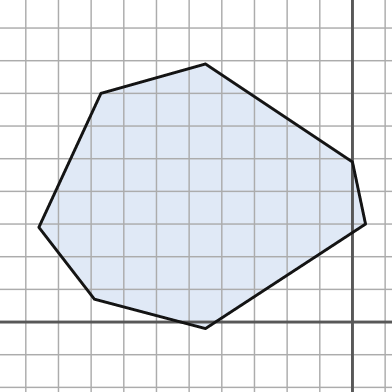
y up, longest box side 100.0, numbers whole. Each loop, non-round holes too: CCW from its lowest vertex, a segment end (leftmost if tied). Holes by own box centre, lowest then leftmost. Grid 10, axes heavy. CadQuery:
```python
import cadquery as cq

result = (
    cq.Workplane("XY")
    .moveTo(-45.0, -2.0)
    .lineTo(4.0, 30.0)
    .lineTo(0.0, 49.0)
    .lineTo(-45.0, 79.0)
    .lineTo(-77.0, 70.0)
    .lineTo(-96.0, 29.0)
    .lineTo(-79.0, 7.0)
    .close()
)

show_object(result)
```